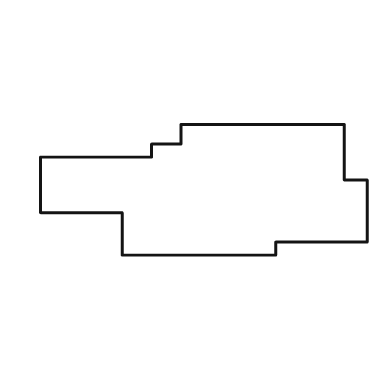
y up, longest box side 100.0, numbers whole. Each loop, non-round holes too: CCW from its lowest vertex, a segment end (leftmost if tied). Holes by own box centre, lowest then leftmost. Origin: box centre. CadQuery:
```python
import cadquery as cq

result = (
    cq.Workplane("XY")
    .moveTo(-25.0, -20.0)
    .lineTo(22.0, -20.0)
    .lineTo(22.0, -16.0)
    .lineTo(50.0, -16.0)
    .lineTo(50.0, 3.0)
    .lineTo(43.0, 3.0)
    .lineTo(43.0, 20.0)
    .lineTo(-7.0, 20.0)
    .lineTo(-7.0, 14.0)
    .lineTo(-16.0, 14.0)
    .lineTo(-16.0, 10.0)
    .lineTo(-50.0, 10.0)
    .lineTo(-50.0, -7.0)
    .lineTo(-25.0, -7.0)
    .close()
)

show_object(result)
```